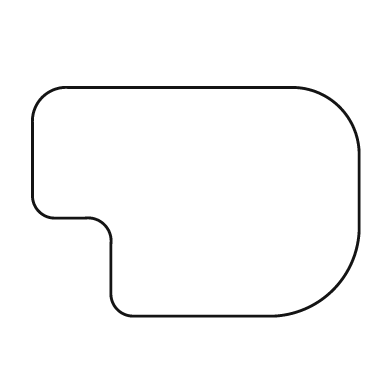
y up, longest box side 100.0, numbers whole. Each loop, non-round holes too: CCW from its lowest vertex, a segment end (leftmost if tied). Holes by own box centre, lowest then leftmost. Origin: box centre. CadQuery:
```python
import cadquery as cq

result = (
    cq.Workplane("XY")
    .moveTo(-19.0, -35.0)
    .lineTo(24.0, -35.0)
    .threePointArc((42.0, -27.0), (50.0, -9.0))
    .lineTo(50.0, 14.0)
    .threePointArc((44.0, 29.0), (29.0, 35.0))
    .lineTo(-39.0, 35.0)
    .threePointArc((-47.0, 32.0), (-50.0, 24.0))
    .lineTo(-50.0, 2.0)
    .threePointArc((-48.0, -3.0), (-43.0, -5.0))
    .lineTo(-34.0, -5.0)
    .threePointArc((-28.0, -7.0), (-26.0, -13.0))
    .lineTo(-26.0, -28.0)
    .threePointArc((-24.0, -33.0), (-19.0, -35.0))
    .close()
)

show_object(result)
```